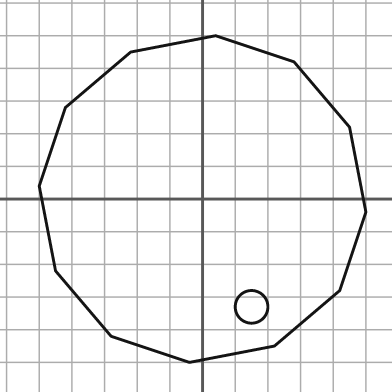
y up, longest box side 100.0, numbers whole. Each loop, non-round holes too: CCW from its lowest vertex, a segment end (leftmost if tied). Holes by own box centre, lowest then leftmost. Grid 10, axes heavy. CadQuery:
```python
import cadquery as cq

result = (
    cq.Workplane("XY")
    .moveTo(-4.0, -50.0)
    .lineTo(22.0, -45.0)
    .lineTo(42.0, -28.0)
    .lineTo(50.0, -4.0)
    .lineTo(45.0, 22.0)
    .lineTo(28.0, 42.0)
    .lineTo(4.0, 50.0)
    .lineTo(-22.0, 45.0)
    .lineTo(-42.0, 28.0)
    .lineTo(-50.0, 4.0)
    .lineTo(-45.0, -22.0)
    .lineTo(-28.0, -42.0)
    .close()
    .moveTo(15.0, -33.0)
    .circle(5.0)
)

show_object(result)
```